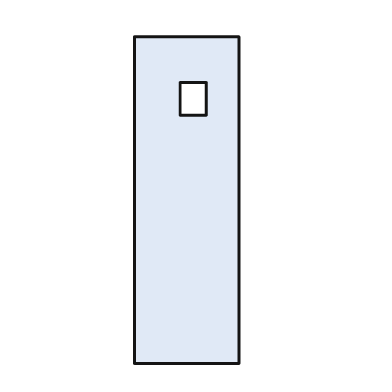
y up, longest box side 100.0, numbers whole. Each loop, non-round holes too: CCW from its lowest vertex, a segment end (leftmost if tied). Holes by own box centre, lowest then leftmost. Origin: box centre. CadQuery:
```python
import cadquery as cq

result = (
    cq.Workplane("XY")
    .moveTo(-16.0, -50.0)
    .lineTo(16.0, -50.0)
    .lineTo(16.0, 50.0)
    .lineTo(-16.0, 50.0)
    .close()
    .moveTo(-2.0, 26.0)
    .lineTo(6.0, 26.0)
    .lineTo(6.0, 36.0)
    .lineTo(-2.0, 36.0)
    .close()
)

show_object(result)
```